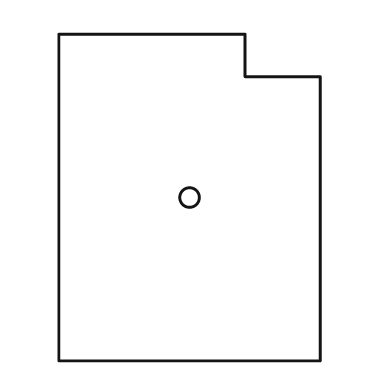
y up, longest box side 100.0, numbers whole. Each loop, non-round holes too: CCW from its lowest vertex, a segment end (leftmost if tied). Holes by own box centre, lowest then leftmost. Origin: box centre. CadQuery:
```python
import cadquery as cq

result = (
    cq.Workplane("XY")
    .moveTo(-40.0, -50.0)
    .lineTo(40.0, -50.0)
    .lineTo(40.0, 37.0)
    .lineTo(17.0, 37.0)
    .lineTo(17.0, 50.0)
    .lineTo(-40.0, 50.0)
    .close()
    .moveTo(0.0, 0.0)
    .circle(3.0)
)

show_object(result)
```